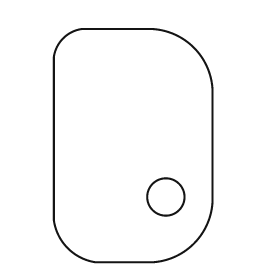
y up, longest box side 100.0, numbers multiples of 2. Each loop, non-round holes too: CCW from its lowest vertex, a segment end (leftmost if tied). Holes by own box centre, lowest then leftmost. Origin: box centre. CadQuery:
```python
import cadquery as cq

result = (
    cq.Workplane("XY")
    .moveTo(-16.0, -50.0)
    .lineTo(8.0, -50.0)
    .threePointArc((26.0, -42.0), (34.0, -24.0))
    .lineTo(34.0, 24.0)
    .threePointArc((26.0, 42.0), (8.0, 50.0))
    .lineTo(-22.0, 50.0)
    .threePointArc((-30.0, 46.0), (-34.0, 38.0))
    .lineTo(-34.0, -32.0)
    .threePointArc((-28.0, -44.0), (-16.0, -50.0))
    .close()
    .moveTo(14.0, -22.0)
    .circle(8.0)
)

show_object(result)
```